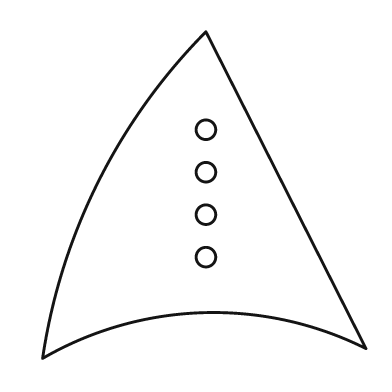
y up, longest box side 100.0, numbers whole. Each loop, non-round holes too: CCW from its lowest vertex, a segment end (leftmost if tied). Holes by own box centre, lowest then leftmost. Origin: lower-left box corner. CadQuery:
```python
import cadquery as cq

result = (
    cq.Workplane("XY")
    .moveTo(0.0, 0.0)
    .threePointArc((49.0, 14.0), (99.0, 3.0))
    .lineTo(50.0, 100.0)
    .threePointArc((17.0, 54.0), (0.0, 0.0))
    .close()
    .moveTo(50.0, 31.0)
    .circle(3.0)
    .moveTo(50.0, 44.0)
    .circle(3.0)
    .moveTo(50.0, 57.0)
    .circle(3.0)
    .moveTo(50.0, 70.0)
    .circle(3.0)
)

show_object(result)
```